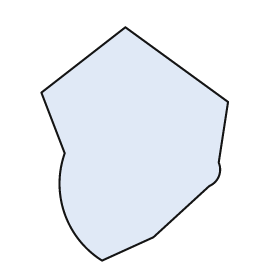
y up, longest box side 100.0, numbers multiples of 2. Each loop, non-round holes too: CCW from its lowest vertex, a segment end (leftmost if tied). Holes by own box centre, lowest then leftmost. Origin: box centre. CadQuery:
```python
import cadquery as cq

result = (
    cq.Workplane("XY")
    .moveTo(-14.0, -50.0)
    .lineTo(8.0, -40.0)
    .lineTo(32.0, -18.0)
    .threePointArc((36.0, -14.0), (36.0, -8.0))
    .lineTo(40.0, 18.0)
    .lineTo(-4.0, 50.0)
    .lineTo(-40.0, 22.0)
    .lineTo(-30.0, -4.0)
    .threePointArc((-30.0, -30.0), (-14.0, -50.0))
    .close()
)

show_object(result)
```